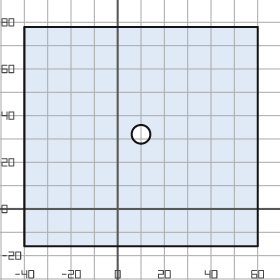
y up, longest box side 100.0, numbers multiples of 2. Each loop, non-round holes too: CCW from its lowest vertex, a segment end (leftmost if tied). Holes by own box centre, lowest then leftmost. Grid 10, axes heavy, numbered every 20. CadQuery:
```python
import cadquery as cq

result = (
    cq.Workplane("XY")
    .moveTo(-40.0, -16.0)
    .lineTo(60.0, -16.0)
    .lineTo(60.0, 78.0)
    .lineTo(-40.0, 78.0)
    .close()
    .moveTo(10.0, 32.0)
    .circle(4.0)
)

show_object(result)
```